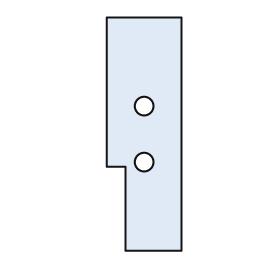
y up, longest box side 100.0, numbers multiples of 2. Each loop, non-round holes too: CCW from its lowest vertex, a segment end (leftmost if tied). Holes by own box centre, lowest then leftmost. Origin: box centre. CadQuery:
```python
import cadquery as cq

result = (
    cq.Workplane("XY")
    .moveTo(-8.0, -50.0)
    .lineTo(16.0, -50.0)
    .lineTo(16.0, 50.0)
    .lineTo(-16.0, 50.0)
    .lineTo(-16.0, -14.0)
    .lineTo(-8.0, -14.0)
    .close()
    .moveTo(0.0, -12.0)
    .circle(4.0)
    .moveTo(0.0, 12.0)
    .circle(4.0)
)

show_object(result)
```